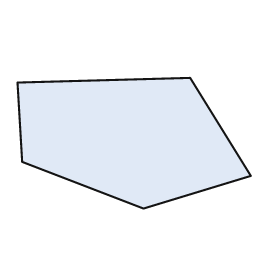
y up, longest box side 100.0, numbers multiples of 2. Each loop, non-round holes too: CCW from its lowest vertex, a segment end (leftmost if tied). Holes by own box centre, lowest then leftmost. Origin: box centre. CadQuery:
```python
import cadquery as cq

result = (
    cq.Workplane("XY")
    .moveTo(4.0, -28.0)
    .lineTo(50.0, -14.0)
    .lineTo(24.0, 28.0)
    .lineTo(-50.0, 26.0)
    .lineTo(-48.0, -8.0)
    .close()
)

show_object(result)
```